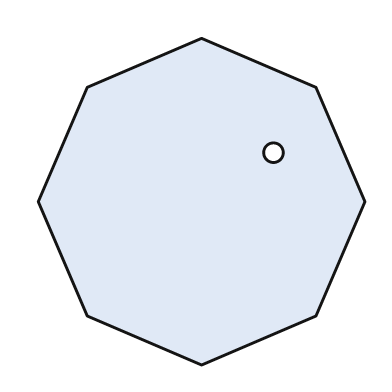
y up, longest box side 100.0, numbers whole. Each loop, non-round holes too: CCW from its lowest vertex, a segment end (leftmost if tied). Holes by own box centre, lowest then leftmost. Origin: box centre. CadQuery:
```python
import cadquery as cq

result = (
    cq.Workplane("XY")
    .moveTo(0.0, -50.0)
    .lineTo(35.0, -35.0)
    .lineTo(50.0, 0.0)
    .lineTo(35.0, 35.0)
    .lineTo(0.0, 50.0)
    .lineTo(-35.0, 35.0)
    .lineTo(-50.0, 0.0)
    .lineTo(-35.0, -35.0)
    .close()
    .moveTo(22.0, 15.0)
    .circle(3.0)
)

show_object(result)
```